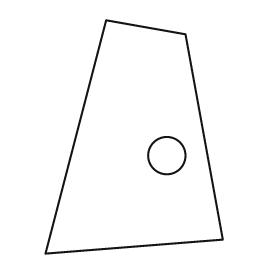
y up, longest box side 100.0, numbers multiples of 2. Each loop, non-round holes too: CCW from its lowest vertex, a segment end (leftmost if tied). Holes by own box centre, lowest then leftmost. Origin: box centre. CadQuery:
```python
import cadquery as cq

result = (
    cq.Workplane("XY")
    .moveTo(-38.0, -50.0)
    .lineTo(38.0, -44.0)
    .lineTo(22.0, 44.0)
    .lineTo(-12.0, 50.0)
    .close()
    .moveTo(14.0, -8.0)
    .circle(8.0)
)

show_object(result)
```